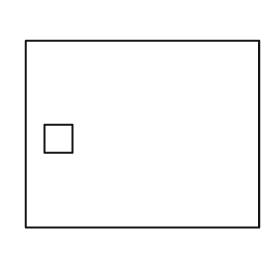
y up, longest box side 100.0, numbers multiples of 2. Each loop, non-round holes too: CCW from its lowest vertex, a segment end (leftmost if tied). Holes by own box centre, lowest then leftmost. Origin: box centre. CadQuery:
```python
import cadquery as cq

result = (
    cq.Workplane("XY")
    .moveTo(-50.0, -40.0)
    .lineTo(50.0, -40.0)
    .lineTo(50.0, 40.0)
    .lineTo(-50.0, 40.0)
    .close()
    .moveTo(-42.0, -8.0)
    .lineTo(-30.0, -8.0)
    .lineTo(-30.0, 4.0)
    .lineTo(-42.0, 4.0)
    .close()
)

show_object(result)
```